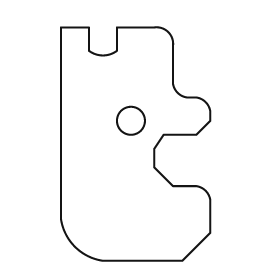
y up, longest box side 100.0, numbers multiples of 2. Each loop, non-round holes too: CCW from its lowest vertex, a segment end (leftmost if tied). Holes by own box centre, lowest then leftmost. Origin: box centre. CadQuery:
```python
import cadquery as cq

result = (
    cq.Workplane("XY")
    .moveTo(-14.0, -50.0)
    .lineTo(20.0, -50.0)
    .lineTo(32.0, -38.0)
    .lineTo(32.0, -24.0)
    .threePointArc((30.0, -20.0), (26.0, -18.0))
    .lineTo(16.0, -18.0)
    .lineTo(8.0, -10.0)
    .lineTo(8.0, -2.0)
    .lineTo(12.0, 4.0)
    .lineTo(26.0, 4.0)
    .lineTo(32.0, 10.0)
    .lineTo(32.0, 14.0)
    .threePointArc((30.0, 18.0), (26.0, 20.0))
    .lineTo(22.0, 20.0)
    .threePointArc((18.0, 22.0), (16.0, 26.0))
    .lineTo(16.0, 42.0)
    .threePointArc((14.0, 48.0), (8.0, 50.0))
    .lineTo(-8.0, 50.0)
    .lineTo(-8.0, 40.0)
    .threePointArc((-14.0, 38.0), (-20.0, 40.0))
    .lineTo(-20.0, 50.0)
    .lineTo(-32.0, 50.0)
    .lineTo(-32.0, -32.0)
    .threePointArc((-26.0, -44.0), (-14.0, -50.0))
    .close()
    .moveTo(-2.0, 10.0)
    .circle(6.0)
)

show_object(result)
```